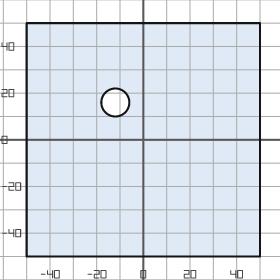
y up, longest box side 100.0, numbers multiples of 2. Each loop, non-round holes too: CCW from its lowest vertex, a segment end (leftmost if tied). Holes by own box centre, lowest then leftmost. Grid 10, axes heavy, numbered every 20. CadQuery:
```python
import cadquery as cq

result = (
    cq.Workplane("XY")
    .moveTo(-50.0, -50.0)
    .lineTo(50.0, -50.0)
    .lineTo(50.0, 50.0)
    .lineTo(-50.0, 50.0)
    .close()
    .moveTo(-12.0, 16.0)
    .circle(6.0)
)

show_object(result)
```